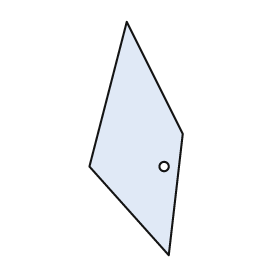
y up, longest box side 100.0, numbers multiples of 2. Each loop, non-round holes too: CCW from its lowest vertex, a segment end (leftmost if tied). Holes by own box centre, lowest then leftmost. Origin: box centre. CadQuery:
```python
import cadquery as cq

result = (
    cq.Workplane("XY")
    .moveTo(14.0, -50.0)
    .lineTo(20.0, 2.0)
    .lineTo(-4.0, 50.0)
    .lineTo(-20.0, -12.0)
    .close()
    .moveTo(12.0, -12.0)
    .circle(2.0)
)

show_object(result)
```